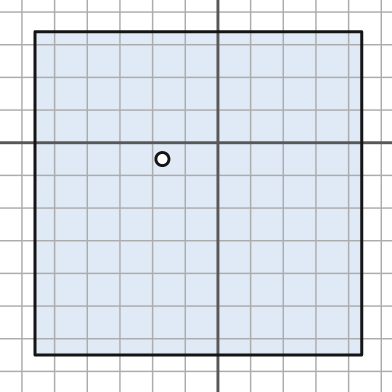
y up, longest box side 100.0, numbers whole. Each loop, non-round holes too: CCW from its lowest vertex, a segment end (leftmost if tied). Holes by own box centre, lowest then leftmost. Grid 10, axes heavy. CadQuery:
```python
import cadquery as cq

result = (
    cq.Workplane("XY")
    .moveTo(-56.0, -65.0)
    .lineTo(44.0, -65.0)
    .lineTo(44.0, 34.0)
    .lineTo(-56.0, 34.0)
    .close()
    .moveTo(-17.0, -5.0)
    .circle(2.0)
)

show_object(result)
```